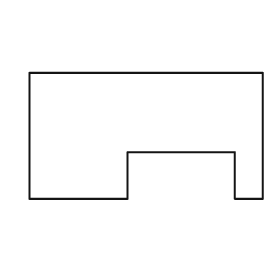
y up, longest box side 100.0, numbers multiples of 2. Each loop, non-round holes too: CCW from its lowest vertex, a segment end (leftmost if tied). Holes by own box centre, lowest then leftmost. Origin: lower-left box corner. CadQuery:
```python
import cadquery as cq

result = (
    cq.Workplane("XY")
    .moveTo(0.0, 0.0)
    .lineTo(42.0, 0.0)
    .lineTo(42.0, 20.0)
    .lineTo(88.0, 20.0)
    .lineTo(88.0, 0.0)
    .lineTo(100.0, 0.0)
    .lineTo(100.0, 54.0)
    .lineTo(0.0, 54.0)
    .close()
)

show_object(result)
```